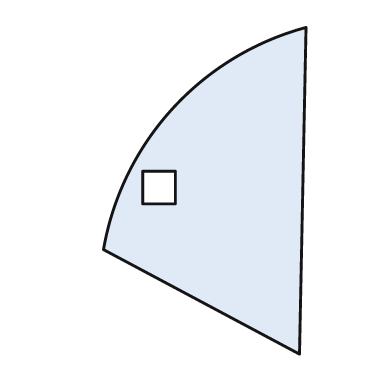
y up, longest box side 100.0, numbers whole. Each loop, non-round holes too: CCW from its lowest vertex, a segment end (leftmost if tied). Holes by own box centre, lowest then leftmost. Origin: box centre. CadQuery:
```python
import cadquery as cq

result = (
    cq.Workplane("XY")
    .moveTo(29.0, -50.0)
    .lineTo(31.0, 50.0)
    .threePointArc((-10.0, 25.0), (-31.0, -18.0))
    .close()
    .moveTo(-19.0, -4.0)
    .lineTo(-9.0, -4.0)
    .lineTo(-9.0, 6.0)
    .lineTo(-19.0, 6.0)
    .close()
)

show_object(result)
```